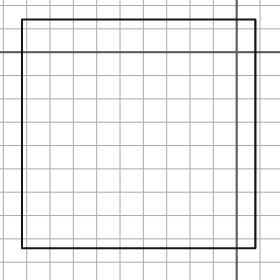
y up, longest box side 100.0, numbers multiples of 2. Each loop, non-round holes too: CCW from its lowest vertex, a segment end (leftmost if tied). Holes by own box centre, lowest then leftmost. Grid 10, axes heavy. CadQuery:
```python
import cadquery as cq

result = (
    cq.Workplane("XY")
    .moveTo(-92.0, -84.0)
    .lineTo(8.0, -84.0)
    .lineTo(8.0, 14.0)
    .lineTo(-92.0, 14.0)
    .close()
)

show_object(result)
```